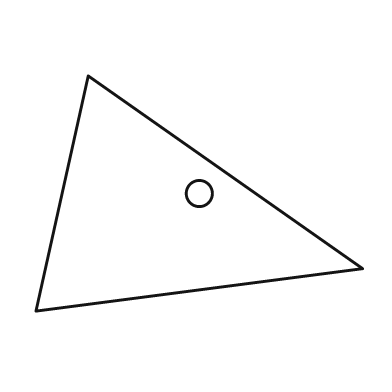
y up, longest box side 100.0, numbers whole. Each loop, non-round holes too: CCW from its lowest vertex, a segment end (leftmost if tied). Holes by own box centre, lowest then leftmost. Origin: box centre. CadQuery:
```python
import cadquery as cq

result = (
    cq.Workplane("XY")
    .moveTo(-50.0, -36.0)
    .lineTo(50.0, -23.0)
    .lineTo(-34.0, 36.0)
    .close()
    .moveTo(0.0, 0.0)
    .circle(4.0)
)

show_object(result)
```